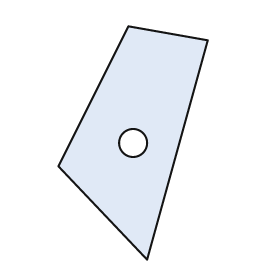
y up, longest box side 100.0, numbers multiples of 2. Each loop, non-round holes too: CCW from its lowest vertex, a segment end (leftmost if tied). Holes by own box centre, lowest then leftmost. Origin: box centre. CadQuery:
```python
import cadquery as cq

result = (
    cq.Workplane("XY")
    .moveTo(6.0, -50.0)
    .lineTo(32.0, 44.0)
    .lineTo(-2.0, 50.0)
    .lineTo(-32.0, -10.0)
    .close()
    .moveTo(0.0, 0.0)
    .circle(6.0)
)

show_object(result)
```